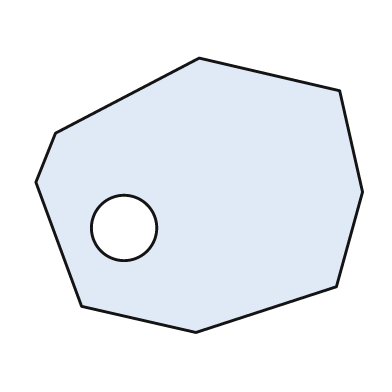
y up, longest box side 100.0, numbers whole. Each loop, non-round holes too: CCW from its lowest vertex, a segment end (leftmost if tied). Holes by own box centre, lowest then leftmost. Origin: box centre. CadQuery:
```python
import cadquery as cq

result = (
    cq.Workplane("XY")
    .moveTo(-1.0, -42.0)
    .lineTo(42.0, -28.0)
    .lineTo(50.0, 1.0)
    .lineTo(43.0, 32.0)
    .lineTo(0.0, 42.0)
    .lineTo(-44.0, 19.0)
    .lineTo(-50.0, 4.0)
    .lineTo(-36.0, -34.0)
    .close()
    .moveTo(-23.0, -10.0)
    .circle(10.0)
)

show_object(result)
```